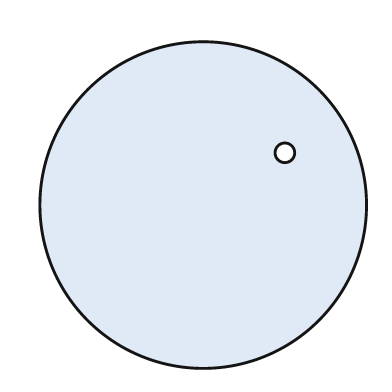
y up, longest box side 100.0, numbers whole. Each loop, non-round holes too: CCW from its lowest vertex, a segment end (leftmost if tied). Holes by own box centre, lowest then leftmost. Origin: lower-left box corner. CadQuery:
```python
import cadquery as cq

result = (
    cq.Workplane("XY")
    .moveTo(50.0, 50.0)
    .circle(50.0)
    .moveTo(75.0, 66.0)
    .circle(3.0)
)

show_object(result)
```